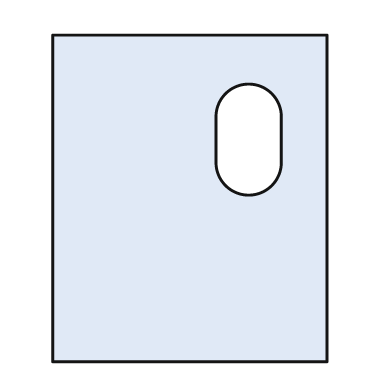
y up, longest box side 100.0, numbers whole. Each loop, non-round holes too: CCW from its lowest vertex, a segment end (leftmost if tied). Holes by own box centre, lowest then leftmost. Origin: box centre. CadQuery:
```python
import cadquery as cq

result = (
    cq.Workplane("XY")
    .moveTo(-42.0, -50.0)
    .lineTo(42.0, -50.0)
    .lineTo(42.0, 50.0)
    .lineTo(-42.0, 50.0)
    .close()
    .moveTo(8.0, 11.0)
    .threePointArc((18.0, 1.0), (28.0, 11.0))
    .lineTo(28.0, 25.0)
    .threePointArc((18.0, 35.0), (8.0, 25.0))
    .close()
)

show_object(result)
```